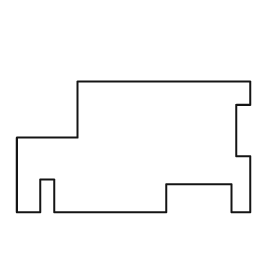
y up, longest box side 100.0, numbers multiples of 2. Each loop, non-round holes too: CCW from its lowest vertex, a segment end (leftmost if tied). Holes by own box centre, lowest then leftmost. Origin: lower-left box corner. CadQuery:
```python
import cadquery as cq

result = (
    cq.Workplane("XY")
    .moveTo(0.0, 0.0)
    .lineTo(10.0, 0.0)
    .lineTo(10.0, 14.0)
    .lineTo(16.0, 14.0)
    .lineTo(16.0, 0.0)
    .lineTo(64.0, 0.0)
    .lineTo(64.0, 12.0)
    .lineTo(92.0, 12.0)
    .lineTo(92.0, 0.0)
    .lineTo(100.0, 0.0)
    .lineTo(100.0, 24.0)
    .lineTo(94.0, 24.0)
    .lineTo(94.0, 46.0)
    .lineTo(100.0, 46.0)
    .lineTo(100.0, 56.0)
    .lineTo(26.0, 56.0)
    .lineTo(26.0, 32.0)
    .lineTo(0.0, 32.0)
    .close()
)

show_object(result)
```